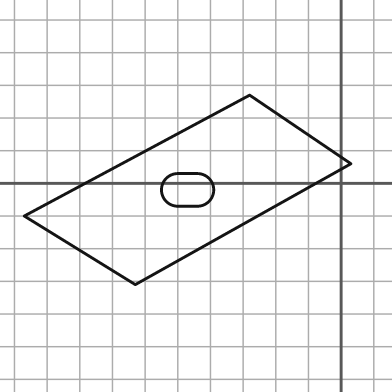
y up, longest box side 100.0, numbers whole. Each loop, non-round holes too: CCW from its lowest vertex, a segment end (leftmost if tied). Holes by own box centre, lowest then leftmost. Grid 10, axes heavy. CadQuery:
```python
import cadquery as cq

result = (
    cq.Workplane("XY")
    .moveTo(-63.0, -31.0)
    .lineTo(3.0, 6.0)
    .lineTo(-28.0, 27.0)
    .lineTo(-97.0, -10.0)
    .close()
    .moveTo(-50.0, -7.0)
    .lineTo(-44.0, -7.0)
    .threePointArc((-39.0, -2.0), (-44.0, 3.0))
    .lineTo(-50.0, 3.0)
    .threePointArc((-55.0, -2.0), (-50.0, -7.0))
    .close()
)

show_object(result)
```